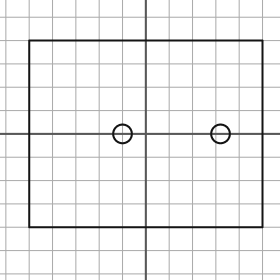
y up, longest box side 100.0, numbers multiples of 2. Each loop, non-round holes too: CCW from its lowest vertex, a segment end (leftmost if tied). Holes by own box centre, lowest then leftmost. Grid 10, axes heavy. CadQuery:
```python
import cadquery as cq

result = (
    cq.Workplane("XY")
    .moveTo(-50.0, -40.0)
    .lineTo(50.0, -40.0)
    .lineTo(50.0, 40.0)
    .lineTo(-50.0, 40.0)
    .close()
    .moveTo(-10.0, 0.0)
    .circle(4.0)
    .moveTo(32.0, 0.0)
    .circle(4.0)
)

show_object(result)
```